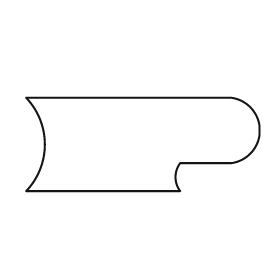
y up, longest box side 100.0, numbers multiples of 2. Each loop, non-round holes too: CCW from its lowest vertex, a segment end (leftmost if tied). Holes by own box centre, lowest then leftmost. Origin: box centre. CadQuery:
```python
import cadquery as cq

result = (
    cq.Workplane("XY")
    .moveTo(-50.0, -20.0)
    .lineTo(16.0, -20.0)
    .threePointArc((14.0, -14.0), (16.0, -8.0))
    .lineTo(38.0, -8.0)
    .threePointArc((46.0, -4.0), (50.0, 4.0))
    .lineTo(50.0, 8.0)
    .threePointArc((46.0, 16.0), (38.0, 20.0))
    .lineTo(-50.0, 20.0)
    .threePointArc((-42.0, 0.0), (-50.0, -20.0))
    .close()
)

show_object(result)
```